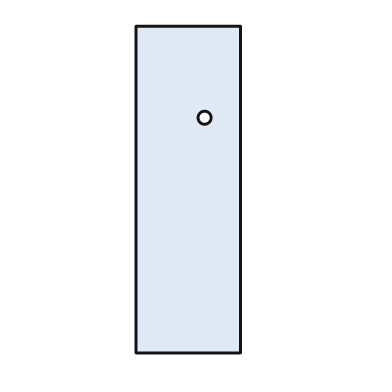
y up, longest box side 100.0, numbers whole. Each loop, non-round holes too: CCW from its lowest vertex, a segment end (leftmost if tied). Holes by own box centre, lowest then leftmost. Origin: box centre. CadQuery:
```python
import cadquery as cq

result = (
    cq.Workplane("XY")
    .moveTo(-16.0, -50.0)
    .lineTo(16.0, -50.0)
    .lineTo(16.0, 50.0)
    .lineTo(-16.0, 50.0)
    .close()
    .moveTo(5.0, 22.0)
    .circle(2.0)
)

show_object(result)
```